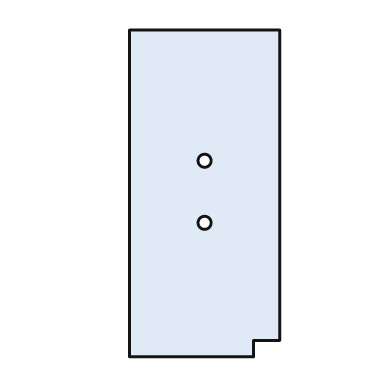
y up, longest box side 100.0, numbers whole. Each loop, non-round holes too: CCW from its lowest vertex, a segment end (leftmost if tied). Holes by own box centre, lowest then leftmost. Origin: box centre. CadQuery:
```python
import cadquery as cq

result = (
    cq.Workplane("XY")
    .moveTo(-23.0, -50.0)
    .lineTo(15.0, -50.0)
    .lineTo(15.0, -45.0)
    .lineTo(23.0, -45.0)
    .lineTo(23.0, 50.0)
    .lineTo(-23.0, 50.0)
    .close()
    .moveTo(0.0, -9.0)
    .circle(2.0)
    .moveTo(0.0, 10.0)
    .circle(2.0)
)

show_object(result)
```